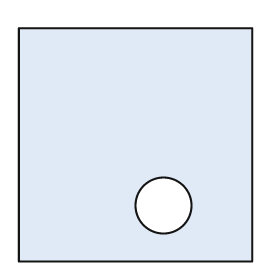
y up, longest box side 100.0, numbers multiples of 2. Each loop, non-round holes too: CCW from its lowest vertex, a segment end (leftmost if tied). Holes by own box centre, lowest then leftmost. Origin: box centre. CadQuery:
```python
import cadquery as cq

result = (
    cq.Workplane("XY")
    .moveTo(-50.0, -50.0)
    .lineTo(50.0, -50.0)
    .lineTo(50.0, 50.0)
    .lineTo(-50.0, 50.0)
    .close()
    .moveTo(12.0, -26.0)
    .circle(12.0)
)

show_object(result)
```